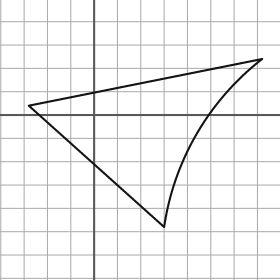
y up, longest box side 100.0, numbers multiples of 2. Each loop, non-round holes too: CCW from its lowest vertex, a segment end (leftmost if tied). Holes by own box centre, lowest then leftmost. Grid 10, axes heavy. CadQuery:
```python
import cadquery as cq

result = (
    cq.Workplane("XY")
    .moveTo(30.0, -48.0)
    .threePointArc((44.0, -8.0), (72.0, 24.0))
    .lineTo(-28.0, 4.0)
    .close()
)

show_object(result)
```